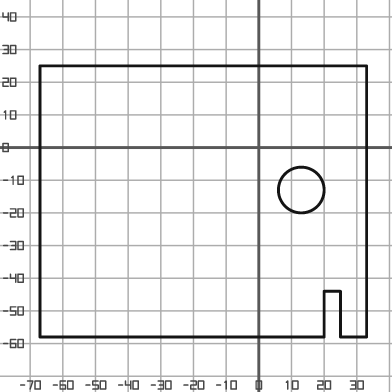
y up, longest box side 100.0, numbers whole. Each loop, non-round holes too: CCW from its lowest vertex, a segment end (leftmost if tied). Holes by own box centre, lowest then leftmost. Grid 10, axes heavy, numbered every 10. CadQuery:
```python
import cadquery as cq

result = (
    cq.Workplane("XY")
    .moveTo(-67.0, -58.0)
    .lineTo(20.0, -58.0)
    .lineTo(20.0, -44.0)
    .lineTo(25.0, -44.0)
    .lineTo(25.0, -58.0)
    .lineTo(33.0, -58.0)
    .lineTo(33.0, 25.0)
    .lineTo(-67.0, 25.0)
    .close()
    .moveTo(13.0, -13.0)
    .circle(7.0)
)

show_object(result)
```